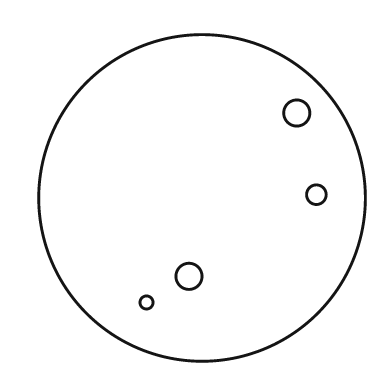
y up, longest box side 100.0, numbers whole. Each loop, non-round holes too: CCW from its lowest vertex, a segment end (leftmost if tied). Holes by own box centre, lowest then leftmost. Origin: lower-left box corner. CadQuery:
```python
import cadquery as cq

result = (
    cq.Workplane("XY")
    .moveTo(50.0, 50.0)
    .circle(50.0)
    .moveTo(33.0, 18.0)
    .circle(2.0)
    .moveTo(46.0, 26.0)
    .circle(4.0)
    .moveTo(85.0, 51.0)
    .circle(3.0)
    .moveTo(79.0, 76.0)
    .circle(4.0)
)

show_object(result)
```